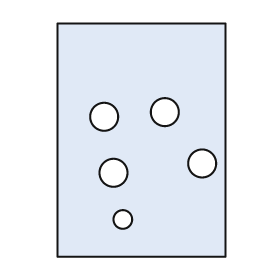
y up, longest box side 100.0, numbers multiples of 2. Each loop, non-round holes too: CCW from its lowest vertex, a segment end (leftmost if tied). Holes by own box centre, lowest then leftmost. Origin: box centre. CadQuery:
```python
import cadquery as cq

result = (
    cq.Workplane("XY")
    .moveTo(-36.0, -50.0)
    .lineTo(36.0, -50.0)
    .lineTo(36.0, 50.0)
    .lineTo(-36.0, 50.0)
    .close()
    .moveTo(-8.0, -34.0)
    .circle(4.0)
    .moveTo(-12.0, -14.0)
    .circle(6.0)
    .moveTo(26.0, -10.0)
    .circle(6.0)
    .moveTo(-16.0, 10.0)
    .circle(6.0)
    .moveTo(10.0, 12.0)
    .circle(6.0)
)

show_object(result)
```